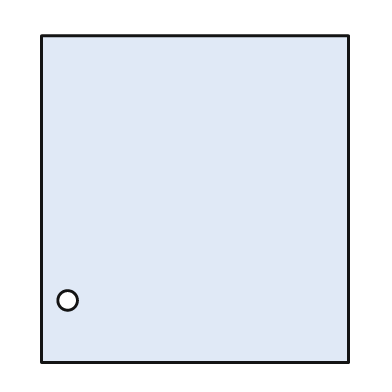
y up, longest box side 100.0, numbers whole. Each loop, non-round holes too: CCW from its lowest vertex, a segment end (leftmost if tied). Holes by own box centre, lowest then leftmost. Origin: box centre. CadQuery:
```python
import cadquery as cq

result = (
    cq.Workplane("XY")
    .moveTo(-47.0, -50.0)
    .lineTo(47.0, -50.0)
    .lineTo(47.0, 50.0)
    .lineTo(-47.0, 50.0)
    .close()
    .moveTo(-39.0, -31.0)
    .circle(3.0)
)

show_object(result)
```